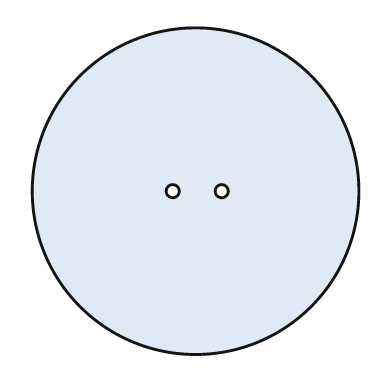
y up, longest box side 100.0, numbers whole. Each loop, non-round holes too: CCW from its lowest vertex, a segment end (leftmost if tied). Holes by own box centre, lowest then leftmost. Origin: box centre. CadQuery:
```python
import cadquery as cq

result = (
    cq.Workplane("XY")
    .moveTo(0.0, 0.0)
    .circle(50.0)
    .moveTo(-7.0, 0.0)
    .circle(2.0)
    .moveTo(8.0, 0.0)
    .circle(2.0)
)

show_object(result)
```